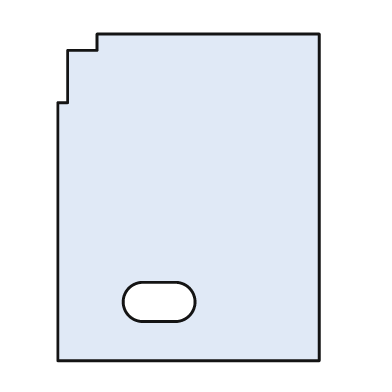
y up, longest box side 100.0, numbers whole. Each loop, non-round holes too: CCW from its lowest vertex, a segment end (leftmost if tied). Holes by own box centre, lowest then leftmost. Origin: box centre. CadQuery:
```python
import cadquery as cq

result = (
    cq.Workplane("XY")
    .moveTo(-40.0, -50.0)
    .lineTo(40.0, -50.0)
    .lineTo(40.0, 50.0)
    .lineTo(-28.0, 50.0)
    .lineTo(-28.0, 45.0)
    .lineTo(-37.0, 45.0)
    .lineTo(-37.0, 29.0)
    .lineTo(-40.0, 29.0)
    .close()
    .moveTo(-14.0, -38.0)
    .lineTo(-4.0, -38.0)
    .threePointArc((2.0, -32.0), (-4.0, -26.0))
    .lineTo(-14.0, -26.0)
    .threePointArc((-20.0, -32.0), (-14.0, -38.0))
    .close()
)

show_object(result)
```